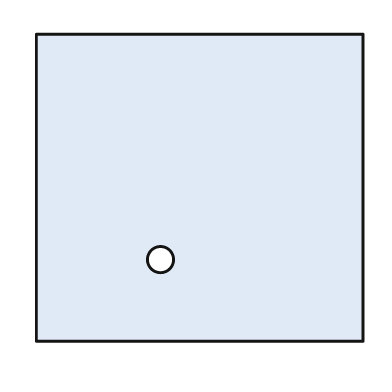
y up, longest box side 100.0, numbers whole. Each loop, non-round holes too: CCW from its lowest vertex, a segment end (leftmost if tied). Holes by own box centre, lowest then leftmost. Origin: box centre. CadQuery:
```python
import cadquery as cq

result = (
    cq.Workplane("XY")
    .moveTo(-50.0, -47.0)
    .lineTo(50.0, -47.0)
    .lineTo(50.0, 47.0)
    .lineTo(-50.0, 47.0)
    .close()
    .moveTo(-12.0, -22.0)
    .circle(4.0)
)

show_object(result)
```